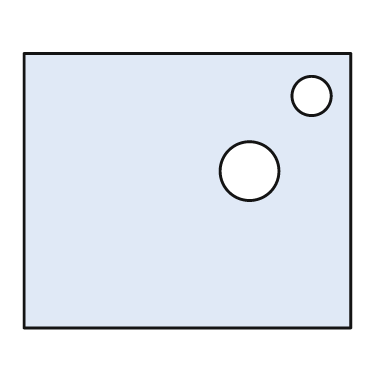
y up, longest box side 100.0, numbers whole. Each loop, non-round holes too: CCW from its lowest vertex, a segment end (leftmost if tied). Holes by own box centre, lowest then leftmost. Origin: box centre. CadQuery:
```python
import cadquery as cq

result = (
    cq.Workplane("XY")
    .moveTo(-50.0, -42.0)
    .lineTo(50.0, -42.0)
    .lineTo(50.0, 42.0)
    .lineTo(-50.0, 42.0)
    .close()
    .moveTo(19.0, 6.0)
    .circle(9.0)
    .moveTo(38.0, 29.0)
    .circle(6.0)
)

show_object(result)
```